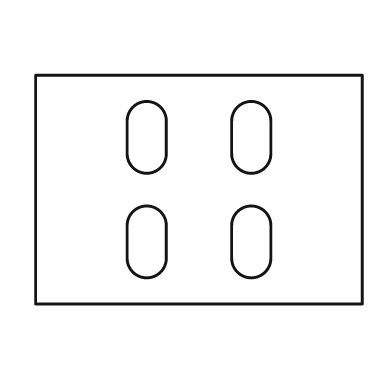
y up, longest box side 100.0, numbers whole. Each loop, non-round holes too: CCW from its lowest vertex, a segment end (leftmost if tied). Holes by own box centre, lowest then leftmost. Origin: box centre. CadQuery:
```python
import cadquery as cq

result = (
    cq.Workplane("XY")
    .moveTo(-50.0, -35.0)
    .lineTo(50.0, -35.0)
    .lineTo(50.0, 35.0)
    .lineTo(-50.0, 35.0)
    .close()
    .moveTo(-22.0, -21.0)
    .threePointArc((-16.0, -27.0), (-10.0, -21.0))
    .lineTo(-10.0, -11.0)
    .threePointArc((-16.0, -5.0), (-22.0, -11.0))
    .close()
    .moveTo(10.0, -21.0)
    .threePointArc((16.0, -27.0), (22.0, -21.0))
    .lineTo(22.0, -11.0)
    .threePointArc((16.0, -5.0), (10.0, -11.0))
    .close()
    .moveTo(-22.0, 11.0)
    .threePointArc((-16.0, 5.0), (-10.0, 11.0))
    .lineTo(-10.0, 21.0)
    .threePointArc((-16.0, 27.0), (-22.0, 21.0))
    .close()
    .moveTo(10.0, 11.0)
    .threePointArc((16.0, 5.0), (22.0, 11.0))
    .lineTo(22.0, 21.0)
    .threePointArc((16.0, 27.0), (10.0, 21.0))
    .close()
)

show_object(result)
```